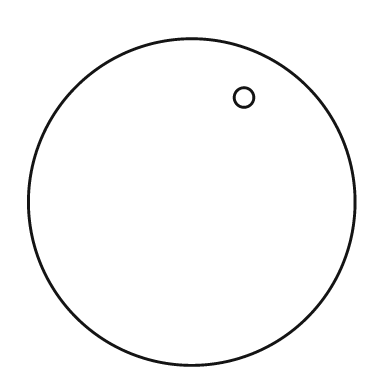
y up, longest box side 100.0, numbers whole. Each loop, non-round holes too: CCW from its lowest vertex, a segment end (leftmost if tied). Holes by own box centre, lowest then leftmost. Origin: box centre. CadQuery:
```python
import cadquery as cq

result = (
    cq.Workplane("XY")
    .moveTo(0.0, 0.0)
    .circle(50.0)
    .moveTo(16.0, 32.0)
    .circle(3.0)
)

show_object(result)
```